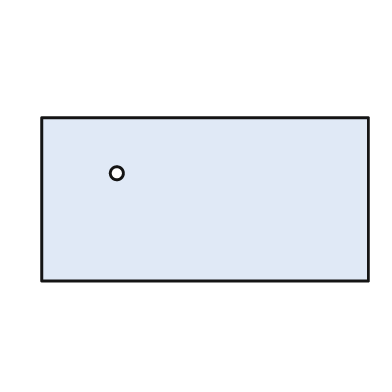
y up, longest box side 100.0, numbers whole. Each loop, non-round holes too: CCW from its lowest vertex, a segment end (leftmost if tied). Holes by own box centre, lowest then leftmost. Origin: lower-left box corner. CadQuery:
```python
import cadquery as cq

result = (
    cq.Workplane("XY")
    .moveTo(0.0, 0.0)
    .lineTo(100.0, 0.0)
    .lineTo(100.0, 50.0)
    .lineTo(0.0, 50.0)
    .close()
    .moveTo(23.0, 33.0)
    .circle(2.0)
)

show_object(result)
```